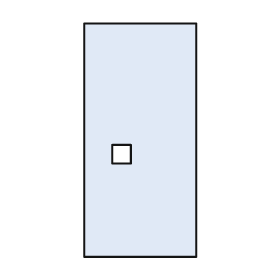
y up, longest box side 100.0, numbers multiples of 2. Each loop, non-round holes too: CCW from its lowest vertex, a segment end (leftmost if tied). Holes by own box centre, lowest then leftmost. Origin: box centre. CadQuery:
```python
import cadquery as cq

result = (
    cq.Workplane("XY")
    .moveTo(-24.0, -50.0)
    .lineTo(24.0, -50.0)
    .lineTo(24.0, 50.0)
    .lineTo(-24.0, 50.0)
    .close()
    .moveTo(-12.0, -10.0)
    .lineTo(-4.0, -10.0)
    .lineTo(-4.0, -2.0)
    .lineTo(-12.0, -2.0)
    .close()
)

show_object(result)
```